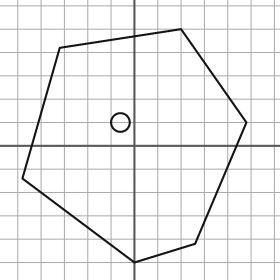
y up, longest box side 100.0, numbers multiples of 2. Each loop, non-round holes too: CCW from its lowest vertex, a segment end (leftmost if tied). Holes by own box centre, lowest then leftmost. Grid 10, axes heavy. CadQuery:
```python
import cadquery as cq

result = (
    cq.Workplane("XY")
    .moveTo(0.0, -50.0)
    .lineTo(26.0, -42.0)
    .lineTo(48.0, 10.0)
    .lineTo(20.0, 50.0)
    .lineTo(-32.0, 42.0)
    .lineTo(-48.0, -14.0)
    .close()
    .moveTo(-6.0, 10.0)
    .circle(4.0)
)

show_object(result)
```